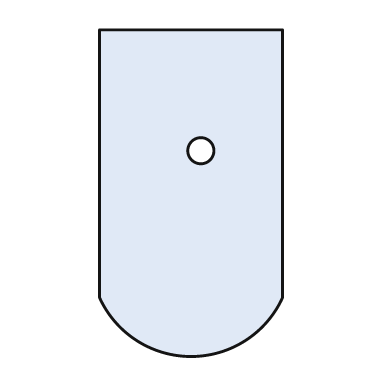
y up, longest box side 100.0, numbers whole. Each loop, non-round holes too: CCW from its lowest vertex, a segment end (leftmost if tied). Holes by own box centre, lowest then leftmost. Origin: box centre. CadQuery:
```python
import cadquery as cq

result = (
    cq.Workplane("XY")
    .moveTo(-28.0, -32.0)
    .threePointArc((0.0, -50.0), (28.0, -32.0))
    .lineTo(28.0, 50.0)
    .lineTo(-28.0, 50.0)
    .close()
    .moveTo(3.0, 13.0)
    .circle(4.0)
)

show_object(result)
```